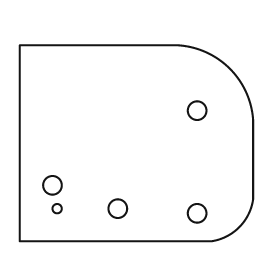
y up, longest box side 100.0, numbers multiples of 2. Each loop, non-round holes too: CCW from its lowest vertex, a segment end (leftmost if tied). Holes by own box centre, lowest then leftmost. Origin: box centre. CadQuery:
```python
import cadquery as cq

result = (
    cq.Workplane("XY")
    .moveTo(-50.0, -42.0)
    .lineTo(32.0, -42.0)
    .threePointArc((44.0, -36.0), (50.0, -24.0))
    .lineTo(50.0, 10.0)
    .threePointArc((40.0, 32.0), (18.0, 42.0))
    .lineTo(-50.0, 42.0)
    .close()
    .moveTo(26.0, -30.0)
    .circle(4.0)
    .moveTo(-34.0, -28.0)
    .circle(2.0)
    .moveTo(-8.0, -28.0)
    .circle(4.0)
    .moveTo(-36.0, -18.0)
    .circle(4.0)
    .moveTo(26.0, 14.0)
    .circle(4.0)
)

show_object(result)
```